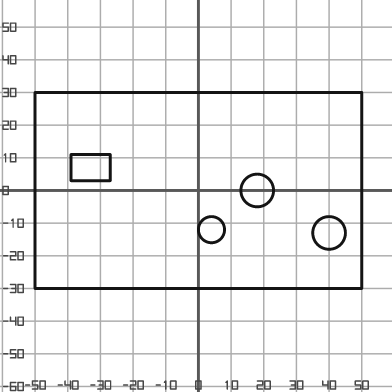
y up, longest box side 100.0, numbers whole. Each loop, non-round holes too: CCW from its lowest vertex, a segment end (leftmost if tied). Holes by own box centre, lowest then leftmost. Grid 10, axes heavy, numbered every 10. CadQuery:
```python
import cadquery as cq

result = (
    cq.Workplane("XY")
    .moveTo(-50.0, -30.0)
    .lineTo(50.0, -30.0)
    .lineTo(50.0, 30.0)
    .lineTo(-50.0, 30.0)
    .close()
    .moveTo(40.0, -13.0)
    .circle(5.0)
    .moveTo(4.0, -12.0)
    .circle(4.0)
    .moveTo(18.0, 0.0)
    .circle(5.0)
    .moveTo(-39.0, 3.0)
    .lineTo(-27.0, 3.0)
    .lineTo(-27.0, 11.0)
    .lineTo(-39.0, 11.0)
    .close()
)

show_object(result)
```